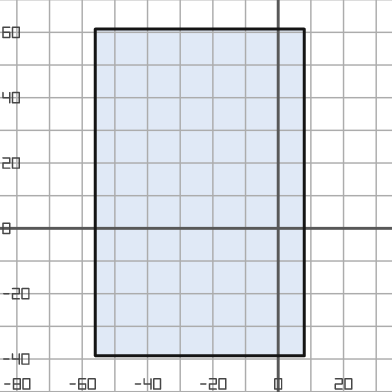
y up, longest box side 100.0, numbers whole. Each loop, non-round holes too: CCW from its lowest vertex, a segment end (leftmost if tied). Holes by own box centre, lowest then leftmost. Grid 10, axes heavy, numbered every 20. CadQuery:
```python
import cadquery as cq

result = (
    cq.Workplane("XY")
    .moveTo(-56.0, -39.0)
    .lineTo(8.0, -39.0)
    .lineTo(8.0, 61.0)
    .lineTo(-56.0, 61.0)
    .close()
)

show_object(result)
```